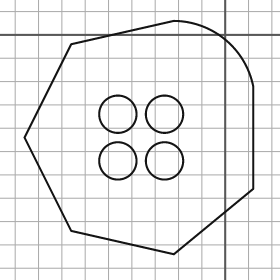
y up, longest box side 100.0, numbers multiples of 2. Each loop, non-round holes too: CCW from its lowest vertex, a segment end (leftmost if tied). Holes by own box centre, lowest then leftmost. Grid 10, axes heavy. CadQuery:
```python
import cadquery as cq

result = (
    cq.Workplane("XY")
    .moveTo(-22.0, -94.0)
    .lineTo(12.0, -66.0)
    .lineTo(12.0, -22.0)
    .threePointArc((0.0, -2.0), (-22.0, 6.0))
    .lineTo(-66.0, -4.0)
    .lineTo(-86.0, -44.0)
    .lineTo(-66.0, -84.0)
    .close()
    .moveTo(-46.0, -54.0)
    .circle(8.0)
    .moveTo(-26.0, -54.0)
    .circle(8.0)
    .moveTo(-46.0, -34.0)
    .circle(8.0)
    .moveTo(-26.0, -34.0)
    .circle(8.0)
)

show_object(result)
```